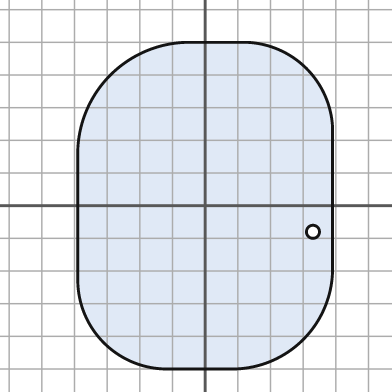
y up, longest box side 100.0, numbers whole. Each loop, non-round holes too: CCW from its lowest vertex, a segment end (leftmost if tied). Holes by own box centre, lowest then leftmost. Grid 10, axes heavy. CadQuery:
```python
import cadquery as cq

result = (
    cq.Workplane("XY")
    .moveTo(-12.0, -50.0)
    .lineTo(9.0, -50.0)
    .threePointArc((30.0, -41.0), (39.0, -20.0))
    .lineTo(39.0, 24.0)
    .threePointArc((31.0, 42.0), (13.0, 50.0))
    .lineTo(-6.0, 50.0)
    .threePointArc((-29.0, 40.0), (-39.0, 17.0))
    .lineTo(-39.0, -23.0)
    .threePointArc((-31.0, -42.0), (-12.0, -50.0))
    .close()
    .moveTo(33.0, -8.0)
    .circle(2.0)
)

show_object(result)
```